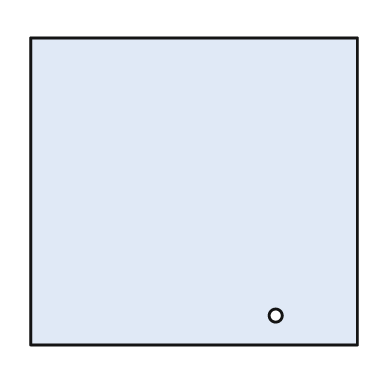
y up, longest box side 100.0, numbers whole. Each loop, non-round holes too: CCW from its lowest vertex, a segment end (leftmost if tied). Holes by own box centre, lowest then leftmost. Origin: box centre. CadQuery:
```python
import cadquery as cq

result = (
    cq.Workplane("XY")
    .moveTo(-50.0, -47.0)
    .lineTo(50.0, -47.0)
    .lineTo(50.0, 47.0)
    .lineTo(-50.0, 47.0)
    .close()
    .moveTo(25.0, -38.0)
    .circle(2.0)
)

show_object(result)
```